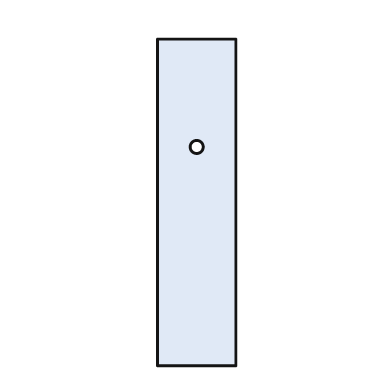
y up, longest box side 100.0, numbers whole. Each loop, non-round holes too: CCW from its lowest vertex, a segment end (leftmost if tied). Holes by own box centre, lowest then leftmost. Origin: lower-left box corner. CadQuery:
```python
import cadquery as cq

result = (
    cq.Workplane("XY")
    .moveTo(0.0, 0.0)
    .lineTo(24.0, 0.0)
    .lineTo(24.0, 100.0)
    .lineTo(0.0, 100.0)
    .close()
    .moveTo(12.0, 67.0)
    .circle(2.0)
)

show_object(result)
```